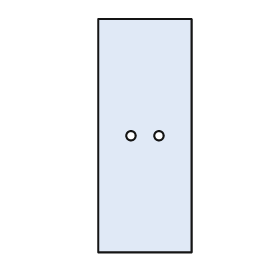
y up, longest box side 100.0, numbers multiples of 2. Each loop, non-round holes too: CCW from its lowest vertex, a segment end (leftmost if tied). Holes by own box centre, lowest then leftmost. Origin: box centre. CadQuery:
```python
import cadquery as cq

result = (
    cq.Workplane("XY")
    .moveTo(-20.0, -50.0)
    .lineTo(20.0, -50.0)
    .lineTo(20.0, 50.0)
    .lineTo(-20.0, 50.0)
    .close()
    .moveTo(-6.0, 0.0)
    .circle(2.0)
    .moveTo(6.0, 0.0)
    .circle(2.0)
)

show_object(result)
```